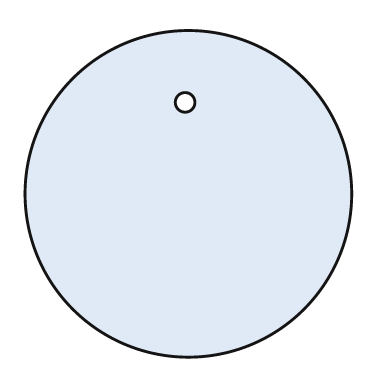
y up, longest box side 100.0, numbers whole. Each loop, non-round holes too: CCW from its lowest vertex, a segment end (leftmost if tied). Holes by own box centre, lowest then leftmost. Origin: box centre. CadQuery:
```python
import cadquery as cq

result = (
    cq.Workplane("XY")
    .moveTo(0.0, 0.0)
    .circle(50.0)
    .moveTo(-1.0, 28.0)
    .circle(3.0)
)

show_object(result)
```